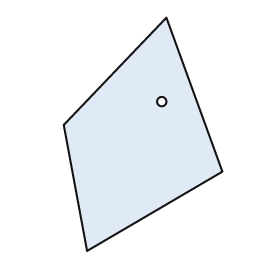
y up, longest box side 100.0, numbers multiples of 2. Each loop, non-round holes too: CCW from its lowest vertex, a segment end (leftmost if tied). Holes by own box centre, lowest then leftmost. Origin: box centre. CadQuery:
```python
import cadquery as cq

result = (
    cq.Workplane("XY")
    .moveTo(-24.0, -50.0)
    .lineTo(34.0, -16.0)
    .lineTo(10.0, 50.0)
    .lineTo(-34.0, 4.0)
    .close()
    .moveTo(8.0, 14.0)
    .circle(2.0)
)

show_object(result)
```